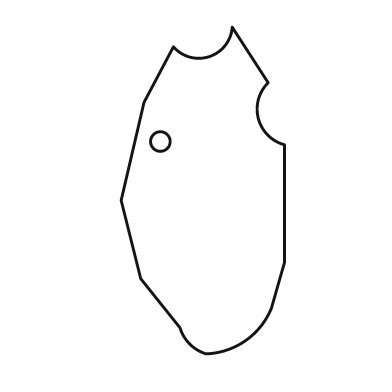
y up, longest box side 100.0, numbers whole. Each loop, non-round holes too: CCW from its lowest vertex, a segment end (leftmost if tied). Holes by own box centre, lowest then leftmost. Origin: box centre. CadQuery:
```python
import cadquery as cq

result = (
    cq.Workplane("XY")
    .moveTo(1.0, -50.0)
    .threePointArc((13.0, -46.0), (21.0, -36.0))
    .lineTo(25.0, -22.0)
    .lineTo(25.0, 14.0)
    .threePointArc((17.0, 22.0), (20.0, 33.0))
    .lineTo(9.0, 50.0)
    .threePointArc((2.0, 41.0), (-9.0, 44.0))
    .lineTo(-18.0, 27.0)
    .lineTo(-25.0, -3.0)
    .lineTo(-19.0, -27.0)
    .lineTo(-7.0, -42.0)
    .threePointArc((-4.0, -47.0), (1.0, -50.0))
    .close()
    .moveTo(-13.0, 15.0)
    .circle(3.0)
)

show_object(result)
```